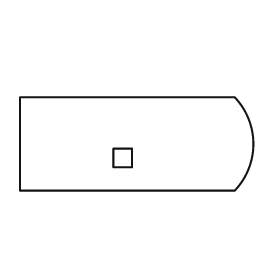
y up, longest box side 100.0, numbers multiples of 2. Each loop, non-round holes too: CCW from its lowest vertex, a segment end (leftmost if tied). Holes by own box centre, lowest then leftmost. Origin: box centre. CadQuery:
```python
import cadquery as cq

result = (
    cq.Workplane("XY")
    .moveTo(-50.0, -20.0)
    .lineTo(42.0, -20.0)
    .threePointArc((50.0, 0.0), (42.0, 20.0))
    .lineTo(-50.0, 20.0)
    .close()
    .moveTo(-10.0, -10.0)
    .lineTo(-2.0, -10.0)
    .lineTo(-2.0, -2.0)
    .lineTo(-10.0, -2.0)
    .close()
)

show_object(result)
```